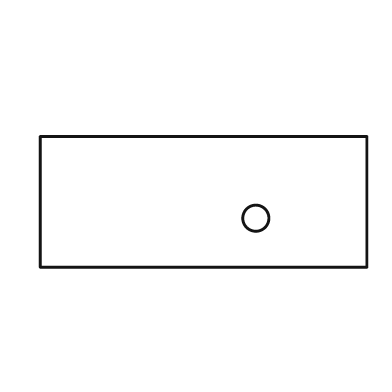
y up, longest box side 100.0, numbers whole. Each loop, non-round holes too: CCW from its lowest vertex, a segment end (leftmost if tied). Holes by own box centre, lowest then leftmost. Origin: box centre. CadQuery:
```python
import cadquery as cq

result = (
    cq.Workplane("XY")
    .moveTo(-50.0, -20.0)
    .lineTo(50.0, -20.0)
    .lineTo(50.0, 20.0)
    .lineTo(-50.0, 20.0)
    .close()
    .moveTo(16.0, -5.0)
    .circle(4.0)
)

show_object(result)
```